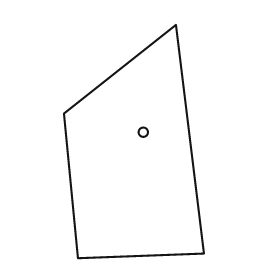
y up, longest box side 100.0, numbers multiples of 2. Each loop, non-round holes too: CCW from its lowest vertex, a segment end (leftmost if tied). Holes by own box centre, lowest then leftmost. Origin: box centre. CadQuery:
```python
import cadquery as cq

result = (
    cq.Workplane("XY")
    .moveTo(-24.0, -50.0)
    .lineTo(30.0, -48.0)
    .lineTo(18.0, 50.0)
    .lineTo(-30.0, 12.0)
    .close()
    .moveTo(4.0, 4.0)
    .circle(2.0)
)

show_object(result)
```